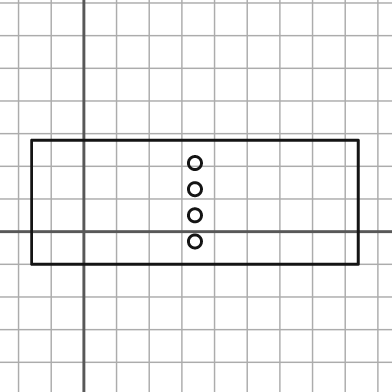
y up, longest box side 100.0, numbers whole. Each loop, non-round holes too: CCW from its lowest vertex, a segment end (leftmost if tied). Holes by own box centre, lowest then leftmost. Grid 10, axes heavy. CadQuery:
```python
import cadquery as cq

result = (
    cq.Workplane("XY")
    .moveTo(-16.0, -10.0)
    .lineTo(84.0, -10.0)
    .lineTo(84.0, 28.0)
    .lineTo(-16.0, 28.0)
    .close()
    .moveTo(34.0, -3.0)
    .circle(2.0)
    .moveTo(34.0, 5.0)
    .circle(2.0)
    .moveTo(34.0, 13.0)
    .circle(2.0)
    .moveTo(34.0, 21.0)
    .circle(2.0)
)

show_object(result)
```